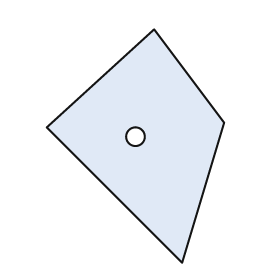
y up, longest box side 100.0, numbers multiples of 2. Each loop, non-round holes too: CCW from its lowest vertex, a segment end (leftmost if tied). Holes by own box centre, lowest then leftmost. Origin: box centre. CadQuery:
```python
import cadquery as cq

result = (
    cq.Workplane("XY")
    .moveTo(20.0, -50.0)
    .lineTo(38.0, 10.0)
    .lineTo(8.0, 50.0)
    .lineTo(-38.0, 8.0)
    .close()
    .moveTo(0.0, 4.0)
    .circle(4.0)
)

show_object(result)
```